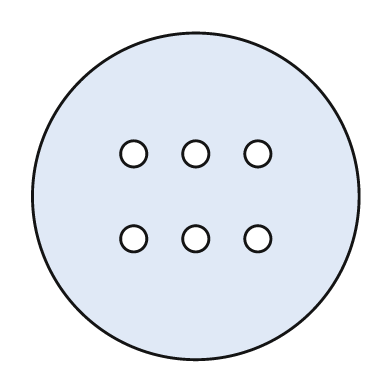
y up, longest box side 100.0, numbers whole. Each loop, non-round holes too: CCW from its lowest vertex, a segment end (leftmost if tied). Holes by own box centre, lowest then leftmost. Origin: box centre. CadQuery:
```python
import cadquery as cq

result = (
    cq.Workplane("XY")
    .moveTo(0.0, 0.0)
    .circle(50.0)
    .moveTo(-19.0, -13.0)
    .circle(4.0)
    .moveTo(0.0, -13.0)
    .circle(4.0)
    .moveTo(19.0, -13.0)
    .circle(4.0)
    .moveTo(-19.0, 13.0)
    .circle(4.0)
    .moveTo(0.0, 13.0)
    .circle(4.0)
    .moveTo(19.0, 13.0)
    .circle(4.0)
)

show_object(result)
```